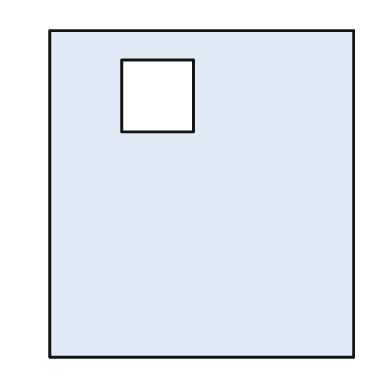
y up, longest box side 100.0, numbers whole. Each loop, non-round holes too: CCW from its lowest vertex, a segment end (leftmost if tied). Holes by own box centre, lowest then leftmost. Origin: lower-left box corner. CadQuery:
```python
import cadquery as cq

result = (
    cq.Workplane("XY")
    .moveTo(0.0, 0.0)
    .lineTo(93.0, 0.0)
    .lineTo(93.0, 100.0)
    .lineTo(0.0, 100.0)
    .close()
    .moveTo(22.0, 69.0)
    .lineTo(44.0, 69.0)
    .lineTo(44.0, 91.0)
    .lineTo(22.0, 91.0)
    .close()
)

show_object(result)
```